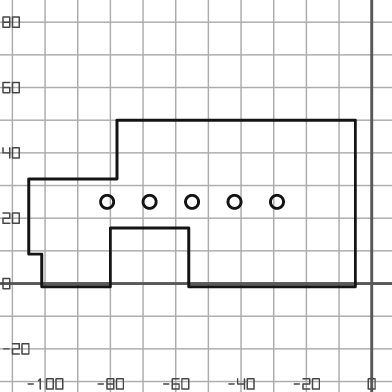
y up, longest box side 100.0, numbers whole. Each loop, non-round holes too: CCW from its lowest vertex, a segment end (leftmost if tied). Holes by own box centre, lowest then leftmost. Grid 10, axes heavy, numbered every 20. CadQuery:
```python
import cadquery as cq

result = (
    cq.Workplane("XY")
    .moveTo(-101.0, -1.0)
    .lineTo(-80.0, -1.0)
    .lineTo(-80.0, 17.0)
    .lineTo(-56.0, 17.0)
    .lineTo(-56.0, -1.0)
    .lineTo(-5.0, -1.0)
    .lineTo(-5.0, 50.0)
    .lineTo(-78.0, 50.0)
    .lineTo(-78.0, 32.0)
    .lineTo(-105.0, 32.0)
    .lineTo(-105.0, 9.0)
    .lineTo(-101.0, 9.0)
    .close()
    .moveTo(-81.0, 25.0)
    .circle(2.0)
    .moveTo(-68.0, 25.0)
    .circle(2.0)
    .moveTo(-55.0, 25.0)
    .circle(2.0)
    .moveTo(-42.0, 25.0)
    .circle(2.0)
    .moveTo(-29.0, 25.0)
    .circle(2.0)
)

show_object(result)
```